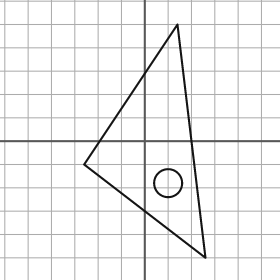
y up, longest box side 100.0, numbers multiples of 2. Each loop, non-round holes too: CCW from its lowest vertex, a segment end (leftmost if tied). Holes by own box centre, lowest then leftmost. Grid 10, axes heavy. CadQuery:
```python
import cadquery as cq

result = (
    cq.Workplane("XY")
    .moveTo(26.0, -50.0)
    .lineTo(14.0, 50.0)
    .lineTo(-26.0, -10.0)
    .close()
    .moveTo(10.0, -18.0)
    .circle(6.0)
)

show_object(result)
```